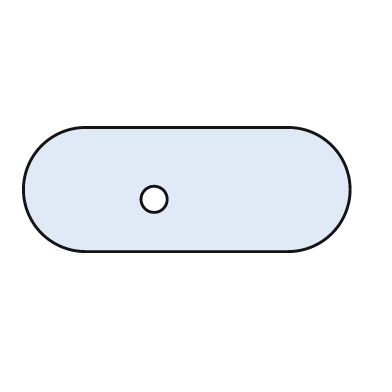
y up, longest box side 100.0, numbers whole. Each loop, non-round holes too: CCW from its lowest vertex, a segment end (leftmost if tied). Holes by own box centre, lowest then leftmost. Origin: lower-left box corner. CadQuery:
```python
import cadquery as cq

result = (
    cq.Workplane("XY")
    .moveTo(19.0, 0.0)
    .lineTo(81.0, 0.0)
    .threePointArc((100.0, 19.0), (81.0, 38.0))
    .lineTo(19.0, 38.0)
    .threePointArc((0.0, 19.0), (19.0, 0.0))
    .close()
    .moveTo(40.0, 16.0)
    .circle(4.0)
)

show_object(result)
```